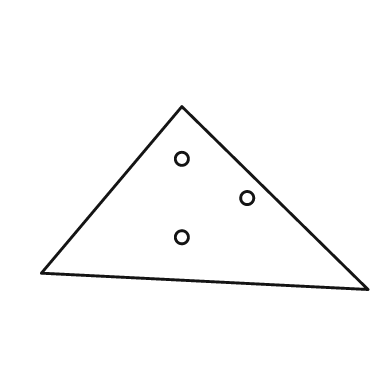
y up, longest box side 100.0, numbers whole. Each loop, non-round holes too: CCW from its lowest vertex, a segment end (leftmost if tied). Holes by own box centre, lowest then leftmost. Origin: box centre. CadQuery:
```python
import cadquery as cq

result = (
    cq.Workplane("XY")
    .moveTo(50.0, -28.0)
    .lineTo(-7.0, 28.0)
    .lineTo(-50.0, -23.0)
    .close()
    .moveTo(-7.0, -12.0)
    .circle(2.0)
    .moveTo(13.0, 0.0)
    .circle(2.0)
    .moveTo(-7.0, 12.0)
    .circle(2.0)
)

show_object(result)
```